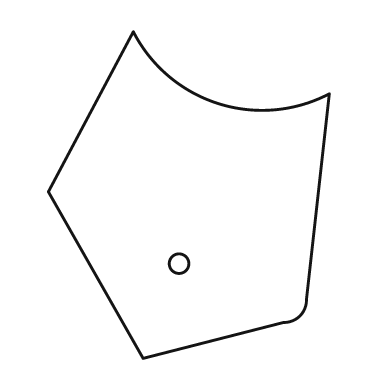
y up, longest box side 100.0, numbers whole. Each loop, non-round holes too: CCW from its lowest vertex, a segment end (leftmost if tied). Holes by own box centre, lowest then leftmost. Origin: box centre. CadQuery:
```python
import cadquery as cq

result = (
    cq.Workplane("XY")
    .moveTo(-14.0, -50.0)
    .lineTo(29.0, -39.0)
    .threePointArc((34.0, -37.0), (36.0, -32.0))
    .lineTo(43.0, 31.0)
    .threePointArc((9.0, 28.0), (-17.0, 50.0))
    .lineTo(-43.0, 1.0)
    .close()
    .moveTo(-3.0, -21.0)
    .circle(3.0)
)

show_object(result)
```